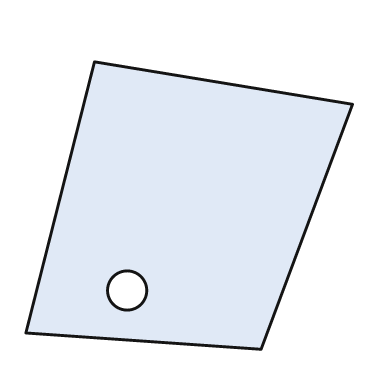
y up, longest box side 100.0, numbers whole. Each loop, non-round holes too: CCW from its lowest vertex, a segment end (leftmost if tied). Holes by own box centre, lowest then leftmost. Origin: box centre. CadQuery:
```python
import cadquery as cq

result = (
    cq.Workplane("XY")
    .moveTo(22.0, -44.0)
    .lineTo(50.0, 31.0)
    .lineTo(-29.0, 44.0)
    .lineTo(-50.0, -39.0)
    .close()
    .moveTo(-19.0, -26.0)
    .circle(6.0)
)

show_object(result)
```